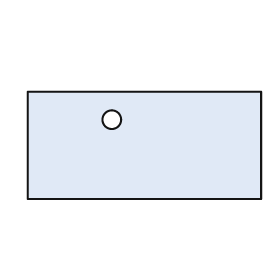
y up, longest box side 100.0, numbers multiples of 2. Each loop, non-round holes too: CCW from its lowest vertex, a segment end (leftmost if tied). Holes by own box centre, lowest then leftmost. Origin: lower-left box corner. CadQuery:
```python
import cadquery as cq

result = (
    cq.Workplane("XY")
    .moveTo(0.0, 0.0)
    .lineTo(100.0, 0.0)
    .lineTo(100.0, 46.0)
    .lineTo(0.0, 46.0)
    .close()
    .moveTo(36.0, 34.0)
    .circle(4.0)
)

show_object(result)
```